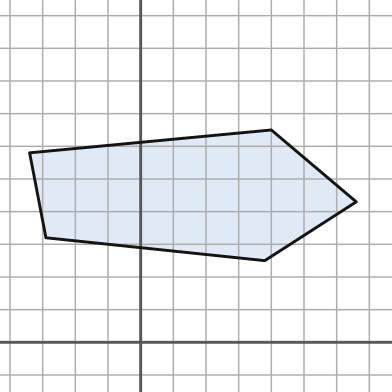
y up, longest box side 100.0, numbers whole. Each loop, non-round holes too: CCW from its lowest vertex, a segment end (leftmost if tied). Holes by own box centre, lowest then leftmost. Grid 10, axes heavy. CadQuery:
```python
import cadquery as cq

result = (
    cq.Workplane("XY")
    .moveTo(38.0, 25.0)
    .lineTo(66.0, 43.0)
    .lineTo(40.0, 65.0)
    .lineTo(-34.0, 58.0)
    .lineTo(-29.0, 32.0)
    .close()
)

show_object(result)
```